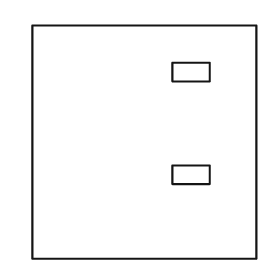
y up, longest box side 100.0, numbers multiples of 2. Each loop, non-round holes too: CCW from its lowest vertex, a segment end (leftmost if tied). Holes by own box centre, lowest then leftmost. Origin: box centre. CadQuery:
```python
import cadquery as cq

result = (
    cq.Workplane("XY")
    .moveTo(-48.0, -50.0)
    .lineTo(48.0, -50.0)
    .lineTo(48.0, 50.0)
    .lineTo(-48.0, 50.0)
    .close()
    .moveTo(12.0, -18.0)
    .lineTo(28.0, -18.0)
    .lineTo(28.0, -10.0)
    .lineTo(12.0, -10.0)
    .close()
    .moveTo(12.0, 26.0)
    .lineTo(28.0, 26.0)
    .lineTo(28.0, 34.0)
    .lineTo(12.0, 34.0)
    .close()
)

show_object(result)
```